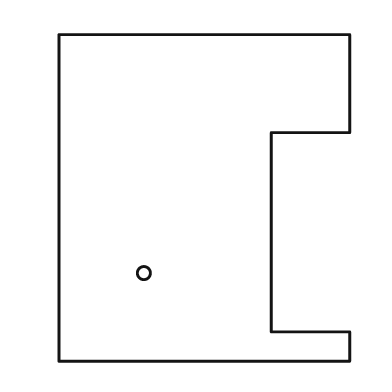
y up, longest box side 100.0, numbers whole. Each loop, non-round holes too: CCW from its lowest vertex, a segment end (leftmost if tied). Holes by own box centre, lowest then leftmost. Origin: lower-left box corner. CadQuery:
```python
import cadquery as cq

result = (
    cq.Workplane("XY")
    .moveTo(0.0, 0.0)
    .lineTo(89.0, 0.0)
    .lineTo(89.0, 9.0)
    .lineTo(65.0, 9.0)
    .lineTo(65.0, 70.0)
    .lineTo(89.0, 70.0)
    .lineTo(89.0, 100.0)
    .lineTo(0.0, 100.0)
    .close()
    .moveTo(26.0, 27.0)
    .circle(2.0)
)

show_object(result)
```